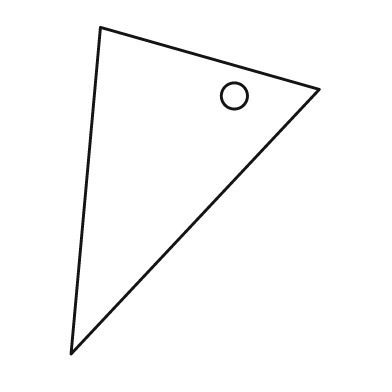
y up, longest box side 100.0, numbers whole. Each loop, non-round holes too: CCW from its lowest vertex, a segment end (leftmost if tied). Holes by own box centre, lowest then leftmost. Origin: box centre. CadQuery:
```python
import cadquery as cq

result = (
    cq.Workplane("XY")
    .moveTo(-38.0, -50.0)
    .lineTo(38.0, 31.0)
    .lineTo(-29.0, 50.0)
    .close()
    .moveTo(12.0, 29.0)
    .circle(4.0)
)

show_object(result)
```